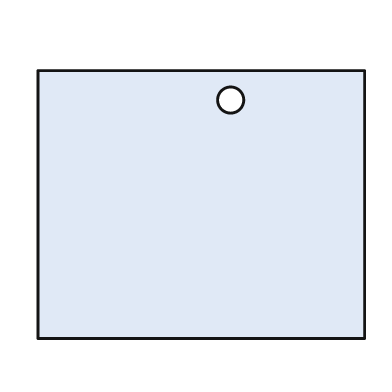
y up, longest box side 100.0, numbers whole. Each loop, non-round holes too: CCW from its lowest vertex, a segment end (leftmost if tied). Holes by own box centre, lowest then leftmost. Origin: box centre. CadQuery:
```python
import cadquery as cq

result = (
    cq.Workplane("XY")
    .moveTo(-50.0, -41.0)
    .lineTo(50.0, -41.0)
    .lineTo(50.0, 41.0)
    .lineTo(-50.0, 41.0)
    .close()
    .moveTo(9.0, 32.0)
    .circle(4.0)
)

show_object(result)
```